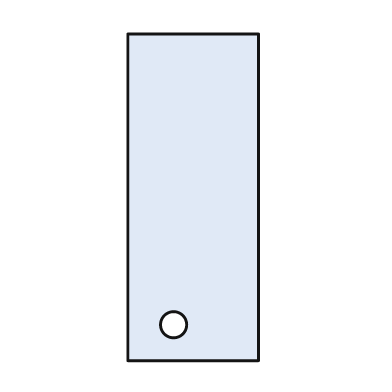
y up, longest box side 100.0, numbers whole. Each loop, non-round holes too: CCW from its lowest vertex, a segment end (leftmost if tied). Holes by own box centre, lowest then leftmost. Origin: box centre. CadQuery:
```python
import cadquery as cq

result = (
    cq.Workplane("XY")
    .moveTo(-20.0, -50.0)
    .lineTo(20.0, -50.0)
    .lineTo(20.0, 50.0)
    .lineTo(-20.0, 50.0)
    .close()
    .moveTo(-6.0, -39.0)
    .circle(4.0)
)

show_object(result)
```